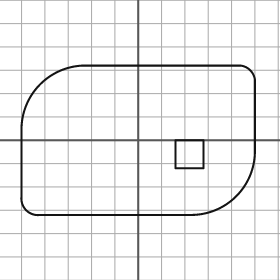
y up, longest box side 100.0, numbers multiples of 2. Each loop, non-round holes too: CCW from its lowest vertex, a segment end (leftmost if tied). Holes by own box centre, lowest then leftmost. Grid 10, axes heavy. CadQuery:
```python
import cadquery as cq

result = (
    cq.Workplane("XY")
    .moveTo(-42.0, -32.0)
    .lineTo(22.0, -32.0)
    .threePointArc((42.0, -24.0), (50.0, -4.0))
    .lineTo(50.0, 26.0)
    .threePointArc((48.0, 30.0), (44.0, 32.0))
    .lineTo(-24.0, 32.0)
    .threePointArc((-42.0, 24.0), (-50.0, 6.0))
    .lineTo(-50.0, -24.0)
    .threePointArc((-48.0, -30.0), (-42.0, -32.0))
    .close()
    .moveTo(16.0, -12.0)
    .lineTo(28.0, -12.0)
    .lineTo(28.0, 0.0)
    .lineTo(16.0, 0.0)
    .close()
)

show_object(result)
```